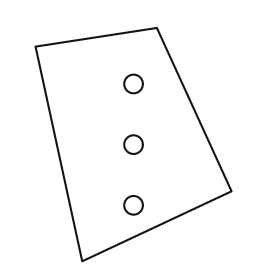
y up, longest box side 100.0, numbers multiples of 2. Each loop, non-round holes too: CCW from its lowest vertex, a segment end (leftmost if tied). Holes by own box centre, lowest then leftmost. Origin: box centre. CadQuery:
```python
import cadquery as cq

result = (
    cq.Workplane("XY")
    .moveTo(-22.0, -50.0)
    .lineTo(42.0, -20.0)
    .lineTo(10.0, 50.0)
    .lineTo(-42.0, 42.0)
    .close()
    .moveTo(0.0, -26.0)
    .circle(4.0)
    .moveTo(0.0, 0.0)
    .circle(4.0)
    .moveTo(0.0, 26.0)
    .circle(4.0)
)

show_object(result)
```